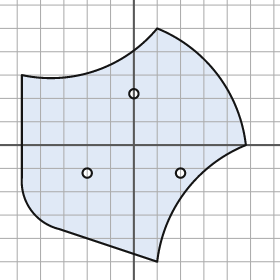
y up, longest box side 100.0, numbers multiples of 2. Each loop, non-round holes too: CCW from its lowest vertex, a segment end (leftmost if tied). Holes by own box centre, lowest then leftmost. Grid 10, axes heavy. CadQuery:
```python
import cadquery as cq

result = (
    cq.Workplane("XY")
    .moveTo(10.0, -50.0)
    .threePointArc((22.0, -20.0), (48.0, 0.0))
    .threePointArc((36.0, 30.0), (10.0, 50.0))
    .threePointArc((-16.0, 32.0), (-48.0, 30.0))
    .lineTo(-48.0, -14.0)
    .threePointArc((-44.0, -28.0), (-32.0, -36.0))
    .close()
    .moveTo(-20.0, -12.0)
    .circle(2.0)
    .moveTo(20.0, -12.0)
    .circle(2.0)
    .moveTo(0.0, 22.0)
    .circle(2.0)
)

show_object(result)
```